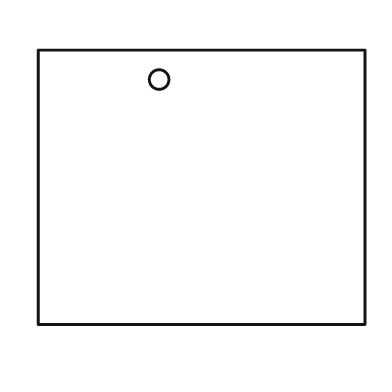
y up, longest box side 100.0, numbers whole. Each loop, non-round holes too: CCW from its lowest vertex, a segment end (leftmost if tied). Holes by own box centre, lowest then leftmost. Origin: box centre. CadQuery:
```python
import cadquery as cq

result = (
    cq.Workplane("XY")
    .moveTo(-50.0, -42.0)
    .lineTo(50.0, -42.0)
    .lineTo(50.0, 42.0)
    .lineTo(-50.0, 42.0)
    .close()
    .moveTo(-13.0, 33.0)
    .circle(3.0)
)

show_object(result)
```